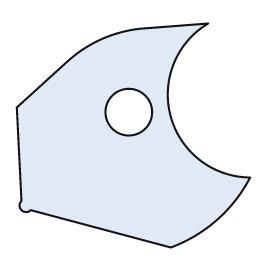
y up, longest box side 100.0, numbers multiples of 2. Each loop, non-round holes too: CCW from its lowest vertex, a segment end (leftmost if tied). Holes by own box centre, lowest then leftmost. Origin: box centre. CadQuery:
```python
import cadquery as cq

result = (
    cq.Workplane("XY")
    .moveTo(16.0, -48.0)
    .threePointArc((36.0, -36.0), (50.0, -18.0))
    .threePointArc((16.0, 8.0), (32.0, 48.0))
    .lineTo(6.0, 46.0)
    .threePointArc((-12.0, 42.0), (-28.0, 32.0))
    .lineTo(-50.0, 12.0)
    .lineTo(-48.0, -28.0)
    .threePointArc((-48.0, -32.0), (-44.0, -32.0))
    .close()
    .moveTo(-2.0, 10.0)
    .circle(10.0)
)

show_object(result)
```